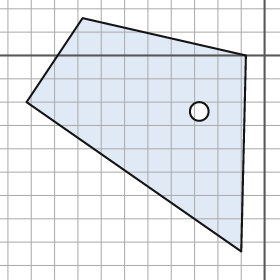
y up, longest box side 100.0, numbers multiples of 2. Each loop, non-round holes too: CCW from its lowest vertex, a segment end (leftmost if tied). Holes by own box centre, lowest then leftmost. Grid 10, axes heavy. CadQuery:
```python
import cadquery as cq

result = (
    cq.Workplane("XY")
    .moveTo(-10.0, -84.0)
    .lineTo(-8.0, 0.0)
    .lineTo(-78.0, 16.0)
    .lineTo(-102.0, -20.0)
    .close()
    .moveTo(-28.0, -24.0)
    .circle(4.0)
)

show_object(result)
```